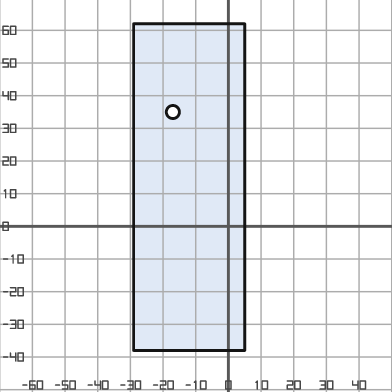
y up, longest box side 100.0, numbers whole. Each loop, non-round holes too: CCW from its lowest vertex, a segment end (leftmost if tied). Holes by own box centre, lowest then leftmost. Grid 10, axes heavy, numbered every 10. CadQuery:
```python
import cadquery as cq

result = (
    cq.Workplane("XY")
    .moveTo(-29.0, -38.0)
    .lineTo(5.0, -38.0)
    .lineTo(5.0, 62.0)
    .lineTo(-29.0, 62.0)
    .close()
    .moveTo(-17.0, 35.0)
    .circle(2.0)
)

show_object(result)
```